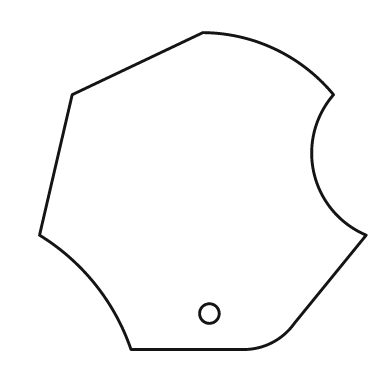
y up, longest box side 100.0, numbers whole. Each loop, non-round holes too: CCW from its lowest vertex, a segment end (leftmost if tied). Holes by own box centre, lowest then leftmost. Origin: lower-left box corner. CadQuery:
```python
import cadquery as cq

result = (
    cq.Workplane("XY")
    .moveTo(28.0, 0.0)
    .lineTo(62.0, 0.0)
    .threePointArc((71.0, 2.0), (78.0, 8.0))
    .lineTo(100.0, 35.0)
    .threePointArc((84.0, 54.0), (90.0, 78.0))
    .threePointArc((72.0, 92.0), (50.0, 97.0))
    .lineTo(10.0, 78.0)
    .lineTo(0.0, 35.0)
    .threePointArc((17.0, 20.0), (28.0, 0.0))
    .close()
    .moveTo(52.0, 11.0)
    .circle(3.0)
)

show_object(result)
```